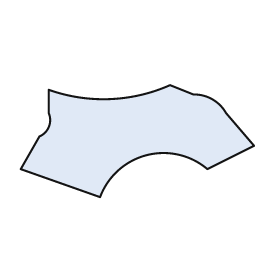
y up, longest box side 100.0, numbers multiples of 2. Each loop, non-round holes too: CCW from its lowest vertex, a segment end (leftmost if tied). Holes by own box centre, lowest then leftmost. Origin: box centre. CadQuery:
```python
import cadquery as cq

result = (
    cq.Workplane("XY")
    .moveTo(-16.0, -24.0)
    .threePointArc((4.0, -6.0), (30.0, -12.0))
    .lineTo(50.0, -2.0)
    .lineTo(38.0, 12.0)
    .threePointArc((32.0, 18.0), (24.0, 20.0))
    .lineTo(14.0, 24.0)
    .threePointArc((-12.0, 18.0), (-38.0, 22.0))
    .lineTo(-38.0, 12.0)
    .threePointArc((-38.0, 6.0), (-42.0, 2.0))
    .lineTo(-50.0, -12.0)
    .close()
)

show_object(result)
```